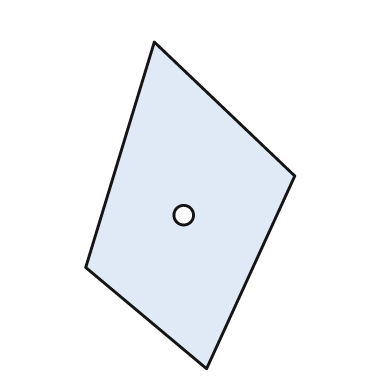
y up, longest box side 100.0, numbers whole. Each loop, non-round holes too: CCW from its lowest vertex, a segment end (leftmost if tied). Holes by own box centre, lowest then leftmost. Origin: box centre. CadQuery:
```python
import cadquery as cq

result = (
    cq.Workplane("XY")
    .moveTo(5.0, -50.0)
    .lineTo(32.0, 9.0)
    .lineTo(-11.0, 50.0)
    .lineTo(-32.0, -19.0)
    .close()
    .moveTo(-2.0, -3.0)
    .circle(3.0)
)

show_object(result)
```